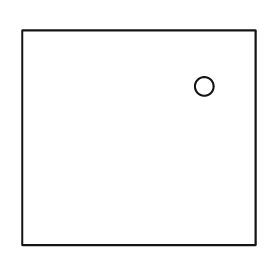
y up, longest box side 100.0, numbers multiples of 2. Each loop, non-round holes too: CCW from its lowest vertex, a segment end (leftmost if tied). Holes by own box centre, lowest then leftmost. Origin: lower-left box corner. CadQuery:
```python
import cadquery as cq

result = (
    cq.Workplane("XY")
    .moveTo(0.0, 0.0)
    .lineTo(100.0, 0.0)
    .lineTo(100.0, 92.0)
    .lineTo(0.0, 92.0)
    .close()
    .moveTo(78.0, 68.0)
    .circle(4.0)
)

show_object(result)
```